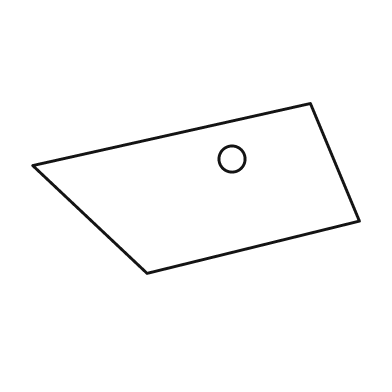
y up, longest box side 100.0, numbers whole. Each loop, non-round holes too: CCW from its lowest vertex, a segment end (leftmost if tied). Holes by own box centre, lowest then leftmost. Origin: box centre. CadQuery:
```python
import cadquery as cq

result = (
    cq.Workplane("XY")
    .moveTo(-15.0, -26.0)
    .lineTo(50.0, -10.0)
    .lineTo(35.0, 26.0)
    .lineTo(-50.0, 7.0)
    .close()
    .moveTo(11.0, 9.0)
    .circle(4.0)
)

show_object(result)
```